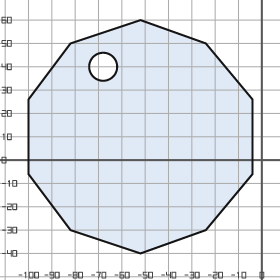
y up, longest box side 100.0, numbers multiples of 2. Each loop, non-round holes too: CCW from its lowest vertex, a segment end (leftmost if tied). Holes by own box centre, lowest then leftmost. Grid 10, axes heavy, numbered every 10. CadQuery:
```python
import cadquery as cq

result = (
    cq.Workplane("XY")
    .moveTo(-52.0, -40.0)
    .lineTo(-24.0, -30.0)
    .lineTo(-4.0, -6.0)
    .lineTo(-4.0, 26.0)
    .lineTo(-24.0, 50.0)
    .lineTo(-52.0, 60.0)
    .lineTo(-82.0, 50.0)
    .lineTo(-100.0, 26.0)
    .lineTo(-100.0, -6.0)
    .lineTo(-82.0, -30.0)
    .close()
    .moveTo(-68.0, 40.0)
    .circle(6.0)
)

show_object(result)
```